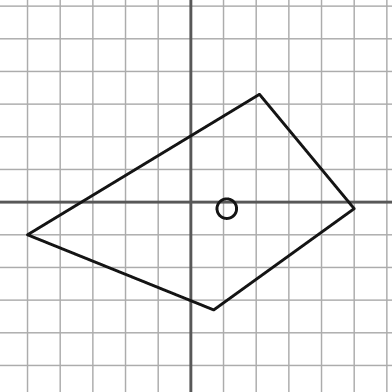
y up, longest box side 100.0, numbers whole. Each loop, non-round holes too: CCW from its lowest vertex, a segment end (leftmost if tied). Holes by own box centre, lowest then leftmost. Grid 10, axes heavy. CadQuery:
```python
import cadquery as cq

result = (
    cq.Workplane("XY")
    .moveTo(7.0, -33.0)
    .lineTo(50.0, -2.0)
    .lineTo(21.0, 33.0)
    .lineTo(-50.0, -10.0)
    .close()
    .moveTo(11.0, -2.0)
    .circle(3.0)
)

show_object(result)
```